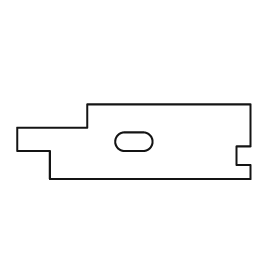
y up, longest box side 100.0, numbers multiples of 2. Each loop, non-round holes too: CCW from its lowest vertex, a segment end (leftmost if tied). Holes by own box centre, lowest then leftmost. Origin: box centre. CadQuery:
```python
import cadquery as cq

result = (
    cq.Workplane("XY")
    .moveTo(-36.0, -16.0)
    .lineTo(50.0, -16.0)
    .lineTo(50.0, -10.0)
    .lineTo(44.0, -10.0)
    .lineTo(44.0, -2.0)
    .lineTo(50.0, -2.0)
    .lineTo(50.0, 16.0)
    .lineTo(-20.0, 16.0)
    .lineTo(-20.0, 6.0)
    .lineTo(-50.0, 6.0)
    .lineTo(-50.0, -4.0)
    .lineTo(-36.0, -4.0)
    .close()
    .moveTo(-4.0, -4.0)
    .lineTo(4.0, -4.0)
    .threePointArc((8.0, 0.0), (4.0, 4.0))
    .lineTo(-4.0, 4.0)
    .threePointArc((-8.0, 0.0), (-4.0, -4.0))
    .close()
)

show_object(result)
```